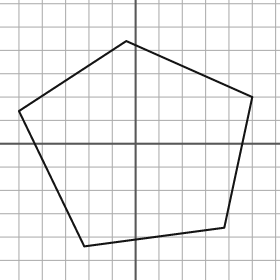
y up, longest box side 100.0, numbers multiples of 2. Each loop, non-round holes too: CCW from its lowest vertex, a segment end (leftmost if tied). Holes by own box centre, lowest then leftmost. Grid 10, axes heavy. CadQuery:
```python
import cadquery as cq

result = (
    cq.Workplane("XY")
    .moveTo(-22.0, -44.0)
    .lineTo(38.0, -36.0)
    .lineTo(50.0, 20.0)
    .lineTo(-4.0, 44.0)
    .lineTo(-50.0, 14.0)
    .close()
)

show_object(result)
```